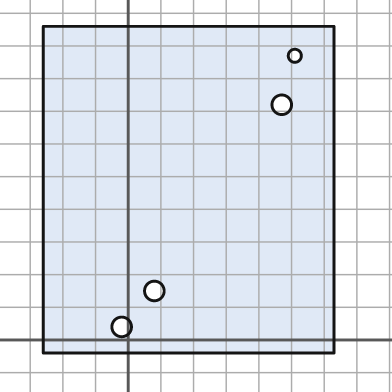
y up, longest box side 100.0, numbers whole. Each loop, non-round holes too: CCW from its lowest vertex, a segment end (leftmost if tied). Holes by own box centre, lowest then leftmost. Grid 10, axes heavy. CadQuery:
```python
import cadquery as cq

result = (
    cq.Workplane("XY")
    .moveTo(-26.0, -4.0)
    .lineTo(63.0, -4.0)
    .lineTo(63.0, 96.0)
    .lineTo(-26.0, 96.0)
    .close()
    .moveTo(-2.0, 4.0)
    .circle(3.0)
    .moveTo(8.0, 15.0)
    .circle(3.0)
    .moveTo(47.0, 72.0)
    .circle(3.0)
    .moveTo(51.0, 87.0)
    .circle(2.0)
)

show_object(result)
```